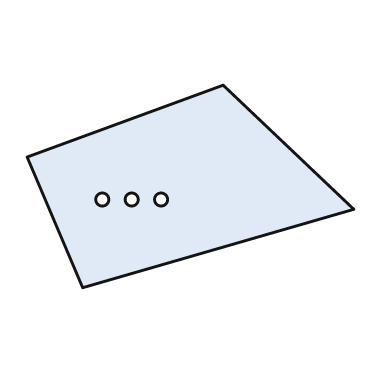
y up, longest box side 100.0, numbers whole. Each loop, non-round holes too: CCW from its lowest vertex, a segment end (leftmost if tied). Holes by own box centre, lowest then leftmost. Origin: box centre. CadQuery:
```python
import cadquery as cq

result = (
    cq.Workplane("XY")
    .moveTo(-33.0, -31.0)
    .lineTo(50.0, -7.0)
    .lineTo(10.0, 31.0)
    .lineTo(-50.0, 9.0)
    .close()
    .moveTo(-27.0, -4.0)
    .circle(2.0)
    .moveTo(-18.0, -4.0)
    .circle(2.0)
    .moveTo(-9.0, -4.0)
    .circle(2.0)
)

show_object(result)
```